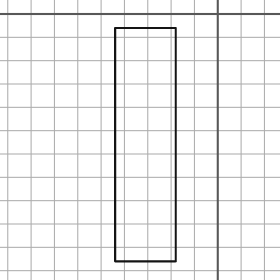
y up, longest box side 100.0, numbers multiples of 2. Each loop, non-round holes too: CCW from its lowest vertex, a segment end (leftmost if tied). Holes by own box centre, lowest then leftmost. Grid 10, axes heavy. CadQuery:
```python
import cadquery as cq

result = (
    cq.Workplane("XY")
    .moveTo(-44.0, -106.0)
    .lineTo(-18.0, -106.0)
    .lineTo(-18.0, -6.0)
    .lineTo(-44.0, -6.0)
    .close()
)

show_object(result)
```